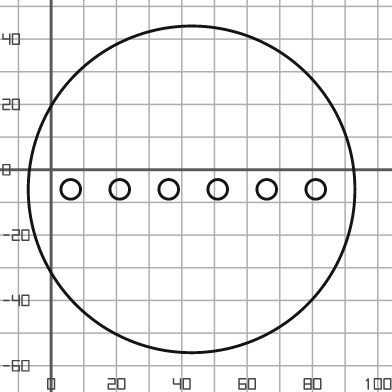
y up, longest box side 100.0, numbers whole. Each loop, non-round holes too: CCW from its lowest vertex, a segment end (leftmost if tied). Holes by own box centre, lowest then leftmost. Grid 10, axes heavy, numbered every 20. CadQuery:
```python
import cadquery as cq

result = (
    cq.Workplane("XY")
    .moveTo(43.0, -6.0)
    .circle(50.0)
    .moveTo(6.0, -6.0)
    .circle(3.0)
    .moveTo(21.0, -6.0)
    .circle(3.0)
    .moveTo(36.0, -6.0)
    .circle(3.0)
    .moveTo(51.0, -6.0)
    .circle(3.0)
    .moveTo(66.0, -6.0)
    .circle(3.0)
    .moveTo(81.0, -6.0)
    .circle(3.0)
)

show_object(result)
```